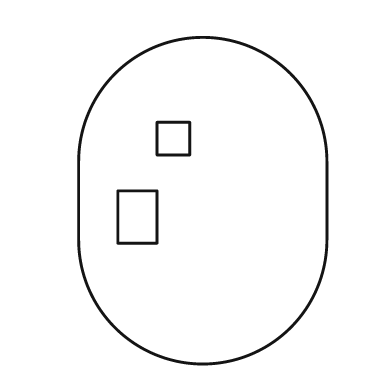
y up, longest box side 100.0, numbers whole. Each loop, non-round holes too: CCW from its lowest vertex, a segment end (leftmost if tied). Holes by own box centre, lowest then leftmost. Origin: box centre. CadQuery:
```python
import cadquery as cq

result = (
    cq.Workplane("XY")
    .moveTo(-38.0, -12.0)
    .threePointArc((0.0, -50.0), (38.0, -12.0))
    .lineTo(38.0, 12.0)
    .threePointArc((0.0, 50.0), (-38.0, 12.0))
    .close()
    .moveTo(-26.0, -13.0)
    .lineTo(-14.0, -13.0)
    .lineTo(-14.0, 3.0)
    .lineTo(-26.0, 3.0)
    .close()
    .moveTo(-14.0, 14.0)
    .lineTo(-4.0, 14.0)
    .lineTo(-4.0, 24.0)
    .lineTo(-14.0, 24.0)
    .close()
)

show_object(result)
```